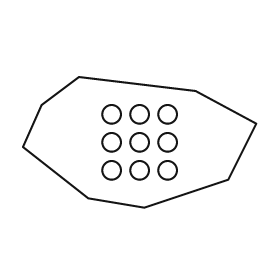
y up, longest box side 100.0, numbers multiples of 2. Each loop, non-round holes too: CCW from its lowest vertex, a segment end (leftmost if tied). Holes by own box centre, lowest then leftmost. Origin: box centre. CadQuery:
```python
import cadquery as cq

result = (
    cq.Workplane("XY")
    .moveTo(2.0, -28.0)
    .lineTo(38.0, -16.0)
    .lineTo(50.0, 8.0)
    .lineTo(24.0, 22.0)
    .lineTo(-26.0, 28.0)
    .lineTo(-42.0, 16.0)
    .lineTo(-50.0, -2.0)
    .lineTo(-22.0, -24.0)
    .close()
    .moveTo(-12.0, -12.0)
    .circle(4.0)
    .moveTo(0.0, -12.0)
    .circle(4.0)
    .moveTo(12.0, -12.0)
    .circle(4.0)
    .moveTo(-12.0, 0.0)
    .circle(4.0)
    .moveTo(0.0, 0.0)
    .circle(4.0)
    .moveTo(12.0, 0.0)
    .circle(4.0)
    .moveTo(-12.0, 12.0)
    .circle(4.0)
    .moveTo(0.0, 12.0)
    .circle(4.0)
    .moveTo(12.0, 12.0)
    .circle(4.0)
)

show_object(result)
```